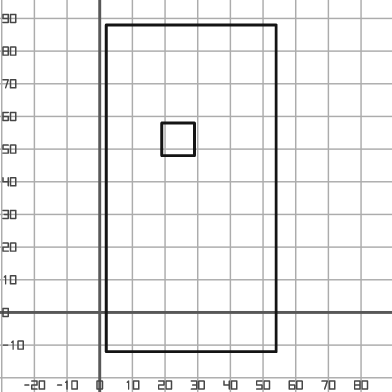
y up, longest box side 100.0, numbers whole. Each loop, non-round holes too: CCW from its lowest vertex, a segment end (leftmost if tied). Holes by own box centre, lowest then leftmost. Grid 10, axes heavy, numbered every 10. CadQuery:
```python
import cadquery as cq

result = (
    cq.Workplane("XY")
    .moveTo(2.0, -12.0)
    .lineTo(54.0, -12.0)
    .lineTo(54.0, 88.0)
    .lineTo(2.0, 88.0)
    .close()
    .moveTo(19.0, 48.0)
    .lineTo(29.0, 48.0)
    .lineTo(29.0, 58.0)
    .lineTo(19.0, 58.0)
    .close()
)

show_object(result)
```